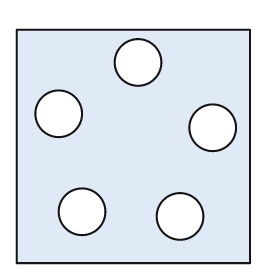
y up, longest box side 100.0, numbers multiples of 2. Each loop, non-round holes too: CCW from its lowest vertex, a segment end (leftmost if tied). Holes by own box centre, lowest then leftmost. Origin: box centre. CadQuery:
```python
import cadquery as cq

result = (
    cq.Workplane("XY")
    .moveTo(-50.0, -50.0)
    .lineTo(50.0, -50.0)
    .lineTo(50.0, 50.0)
    .lineTo(-50.0, 50.0)
    .close()
    .moveTo(20.0, -30.0)
    .circle(10.0)
    .moveTo(-22.0, -28.0)
    .circle(10.0)
    .moveTo(34.0, 8.0)
    .circle(10.0)
    .moveTo(-32.0, 14.0)
    .circle(10.0)
    .moveTo(2.0, 36.0)
    .circle(10.0)
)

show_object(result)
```